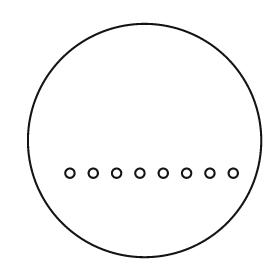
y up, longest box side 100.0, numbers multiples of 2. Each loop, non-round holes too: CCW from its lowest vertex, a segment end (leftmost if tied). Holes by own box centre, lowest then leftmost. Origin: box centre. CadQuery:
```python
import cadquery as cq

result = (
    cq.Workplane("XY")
    .moveTo(0.0, 0.0)
    .circle(50.0)
    .moveTo(-32.0, -14.0)
    .circle(2.0)
    .moveTo(-22.0, -14.0)
    .circle(2.0)
    .moveTo(-12.0, -14.0)
    .circle(2.0)
    .moveTo(-2.0, -14.0)
    .circle(2.0)
    .moveTo(8.0, -14.0)
    .circle(2.0)
    .moveTo(18.0, -14.0)
    .circle(2.0)
    .moveTo(28.0, -14.0)
    .circle(2.0)
    .moveTo(38.0, -14.0)
    .circle(2.0)
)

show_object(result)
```